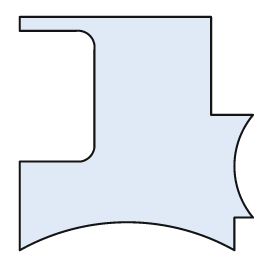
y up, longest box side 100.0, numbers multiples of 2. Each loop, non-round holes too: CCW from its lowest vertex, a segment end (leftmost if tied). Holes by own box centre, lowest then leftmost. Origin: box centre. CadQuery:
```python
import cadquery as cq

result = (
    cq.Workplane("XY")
    .moveTo(-50.0, -50.0)
    .threePointArc((-4.0, -38.0), (42.0, -50.0))
    .lineTo(42.0, -36.0)
    .lineTo(50.0, -36.0)
    .threePointArc((42.0, -14.0), (50.0, 8.0))
    .lineTo(32.0, 8.0)
    .lineTo(32.0, 50.0)
    .lineTo(-50.0, 50.0)
    .lineTo(-50.0, 44.0)
    .lineTo(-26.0, 44.0)
    .threePointArc((-20.0, 42.0), (-18.0, 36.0))
    .lineTo(-18.0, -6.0)
    .threePointArc((-20.0, -10.0), (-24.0, -12.0))
    .lineTo(-50.0, -12.0)
    .close()
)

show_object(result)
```